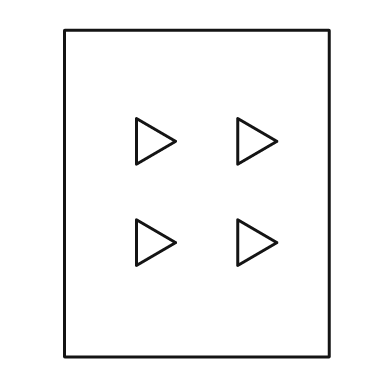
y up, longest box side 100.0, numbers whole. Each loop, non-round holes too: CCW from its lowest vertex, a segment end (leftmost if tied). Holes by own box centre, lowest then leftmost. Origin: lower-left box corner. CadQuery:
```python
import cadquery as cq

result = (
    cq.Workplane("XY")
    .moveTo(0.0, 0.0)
    .lineTo(81.0, 0.0)
    .lineTo(81.0, 100.0)
    .lineTo(0.0, 100.0)
    .close()
    .moveTo(22.0, 28.0)
    .lineTo(34.0, 35.0)
    .lineTo(22.0, 42.0)
    .close()
    .moveTo(53.0, 28.0)
    .lineTo(65.0, 35.0)
    .lineTo(53.0, 42.0)
    .close()
    .moveTo(22.0, 59.0)
    .lineTo(34.0, 66.0)
    .lineTo(22.0, 73.0)
    .close()
    .moveTo(53.0, 59.0)
    .lineTo(65.0, 66.0)
    .lineTo(53.0, 73.0)
    .close()
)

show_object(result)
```